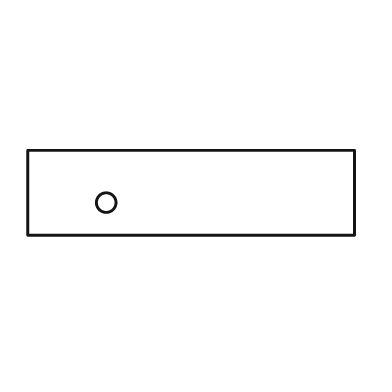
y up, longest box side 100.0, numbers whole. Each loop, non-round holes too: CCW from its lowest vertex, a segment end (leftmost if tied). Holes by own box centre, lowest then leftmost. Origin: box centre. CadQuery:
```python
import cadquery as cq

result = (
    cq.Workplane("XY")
    .moveTo(-50.0, -13.0)
    .lineTo(50.0, -13.0)
    .lineTo(50.0, 13.0)
    .lineTo(-50.0, 13.0)
    .close()
    .moveTo(-26.0, -3.0)
    .circle(3.0)
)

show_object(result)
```